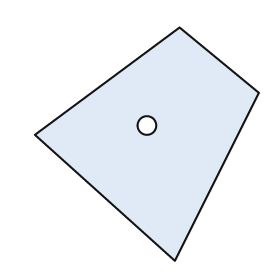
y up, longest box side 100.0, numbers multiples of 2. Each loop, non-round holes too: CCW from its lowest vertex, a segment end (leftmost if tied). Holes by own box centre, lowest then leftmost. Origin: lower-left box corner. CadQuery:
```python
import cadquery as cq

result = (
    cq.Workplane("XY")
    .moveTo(60.0, 0.0)
    .lineTo(96.0, 72.0)
    .lineTo(62.0, 100.0)
    .lineTo(0.0, 54.0)
    .close()
    .moveTo(48.0, 58.0)
    .circle(4.0)
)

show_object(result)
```